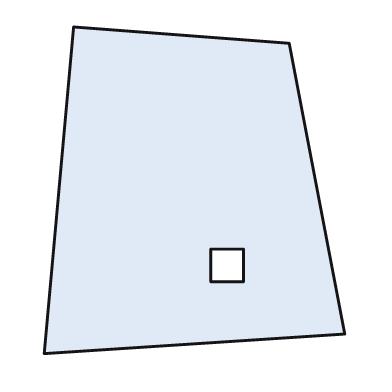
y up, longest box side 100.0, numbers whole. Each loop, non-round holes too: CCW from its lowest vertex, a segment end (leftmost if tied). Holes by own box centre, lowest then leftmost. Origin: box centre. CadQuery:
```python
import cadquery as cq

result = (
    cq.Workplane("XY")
    .moveTo(-46.0, -50.0)
    .lineTo(46.0, -44.0)
    .lineTo(29.0, 45.0)
    .lineTo(-37.0, 50.0)
    .close()
    .moveTo(5.0, -28.0)
    .lineTo(15.0, -28.0)
    .lineTo(15.0, -18.0)
    .lineTo(5.0, -18.0)
    .close()
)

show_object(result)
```